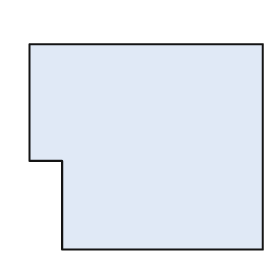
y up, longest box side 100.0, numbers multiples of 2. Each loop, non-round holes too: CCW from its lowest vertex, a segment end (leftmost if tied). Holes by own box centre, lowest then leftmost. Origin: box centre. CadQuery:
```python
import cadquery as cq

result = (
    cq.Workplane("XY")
    .moveTo(-36.0, -44.0)
    .lineTo(50.0, -44.0)
    .lineTo(50.0, 44.0)
    .lineTo(-50.0, 44.0)
    .lineTo(-50.0, -6.0)
    .lineTo(-36.0, -6.0)
    .close()
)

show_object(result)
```